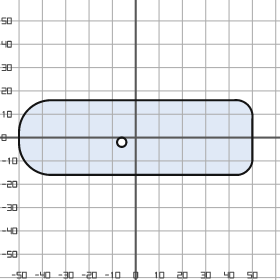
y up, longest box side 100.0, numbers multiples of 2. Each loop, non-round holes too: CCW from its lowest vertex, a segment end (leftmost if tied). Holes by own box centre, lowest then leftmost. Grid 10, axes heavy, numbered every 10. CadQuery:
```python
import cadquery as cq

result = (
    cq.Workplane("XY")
    .moveTo(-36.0, -16.0)
    .lineTo(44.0, -16.0)
    .threePointArc((48.0, -14.0), (50.0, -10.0))
    .lineTo(50.0, 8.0)
    .threePointArc((48.0, 14.0), (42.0, 16.0))
    .lineTo(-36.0, 16.0)
    .threePointArc((-46.0, 12.0), (-50.0, 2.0))
    .lineTo(-50.0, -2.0)
    .threePointArc((-46.0, -12.0), (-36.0, -16.0))
    .close()
    .moveTo(-6.0, -2.0)
    .circle(2.0)
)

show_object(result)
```